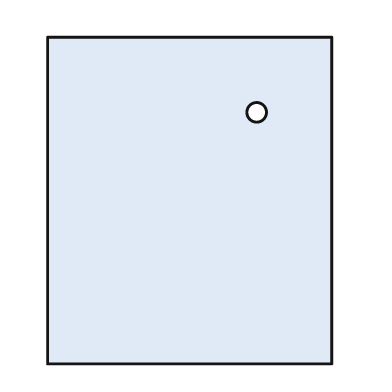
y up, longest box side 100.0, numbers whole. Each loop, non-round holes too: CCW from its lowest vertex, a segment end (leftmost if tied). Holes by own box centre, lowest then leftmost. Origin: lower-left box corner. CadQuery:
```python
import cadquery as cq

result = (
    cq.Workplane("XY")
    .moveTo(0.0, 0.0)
    .lineTo(87.0, 0.0)
    .lineTo(87.0, 100.0)
    .lineTo(0.0, 100.0)
    .close()
    .moveTo(64.0, 77.0)
    .circle(3.0)
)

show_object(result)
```